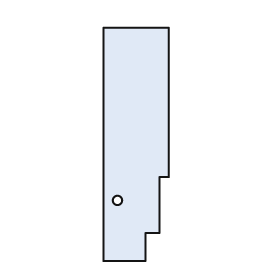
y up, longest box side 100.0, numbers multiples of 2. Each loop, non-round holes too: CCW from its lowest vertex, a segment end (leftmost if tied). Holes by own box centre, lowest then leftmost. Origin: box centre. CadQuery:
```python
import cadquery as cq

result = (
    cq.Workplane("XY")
    .moveTo(-14.0, -50.0)
    .lineTo(4.0, -50.0)
    .lineTo(4.0, -38.0)
    .lineTo(10.0, -38.0)
    .lineTo(10.0, -14.0)
    .lineTo(14.0, -14.0)
    .lineTo(14.0, 50.0)
    .lineTo(-14.0, 50.0)
    .close()
    .moveTo(-8.0, -24.0)
    .circle(2.0)
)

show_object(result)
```